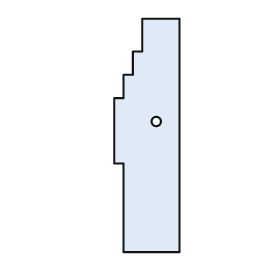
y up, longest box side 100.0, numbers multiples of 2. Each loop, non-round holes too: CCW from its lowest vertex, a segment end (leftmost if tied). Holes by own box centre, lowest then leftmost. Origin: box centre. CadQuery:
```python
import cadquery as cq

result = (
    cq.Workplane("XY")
    .moveTo(-10.0, -50.0)
    .lineTo(14.0, -50.0)
    .lineTo(14.0, 50.0)
    .lineTo(-2.0, 50.0)
    .lineTo(-2.0, 36.0)
    .lineTo(-6.0, 36.0)
    .lineTo(-6.0, 26.0)
    .lineTo(-10.0, 26.0)
    .lineTo(-10.0, 16.0)
    .lineTo(-14.0, 16.0)
    .lineTo(-14.0, -12.0)
    .lineTo(-10.0, -12.0)
    .close()
    .moveTo(4.0, 6.0)
    .circle(2.0)
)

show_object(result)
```